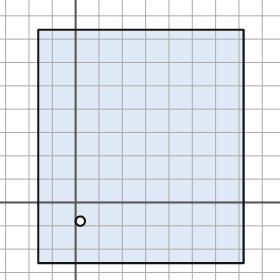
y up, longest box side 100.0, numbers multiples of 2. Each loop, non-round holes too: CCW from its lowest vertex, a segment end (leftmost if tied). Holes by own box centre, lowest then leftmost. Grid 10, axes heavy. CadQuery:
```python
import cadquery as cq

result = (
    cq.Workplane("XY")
    .moveTo(-16.0, -26.0)
    .lineTo(72.0, -26.0)
    .lineTo(72.0, 74.0)
    .lineTo(-16.0, 74.0)
    .close()
    .moveTo(2.0, -8.0)
    .circle(2.0)
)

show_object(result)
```